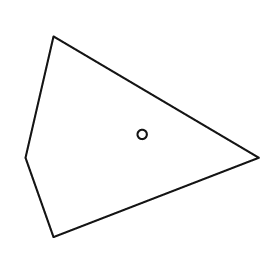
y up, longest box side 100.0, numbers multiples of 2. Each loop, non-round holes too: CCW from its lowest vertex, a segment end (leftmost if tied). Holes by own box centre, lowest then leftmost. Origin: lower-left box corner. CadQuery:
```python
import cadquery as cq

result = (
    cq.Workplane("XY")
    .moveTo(12.0, 0.0)
    .lineTo(100.0, 34.0)
    .lineTo(12.0, 86.0)
    .lineTo(0.0, 34.0)
    .close()
    .moveTo(50.0, 44.0)
    .circle(2.0)
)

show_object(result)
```